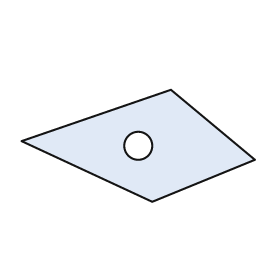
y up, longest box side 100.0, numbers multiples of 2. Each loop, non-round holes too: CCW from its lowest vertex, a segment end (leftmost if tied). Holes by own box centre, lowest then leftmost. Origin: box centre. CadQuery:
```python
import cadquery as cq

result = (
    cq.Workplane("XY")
    .moveTo(6.0, -24.0)
    .lineTo(50.0, -6.0)
    .lineTo(14.0, 24.0)
    .lineTo(-50.0, 2.0)
    .close()
    .moveTo(0.0, 0.0)
    .circle(6.0)
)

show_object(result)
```